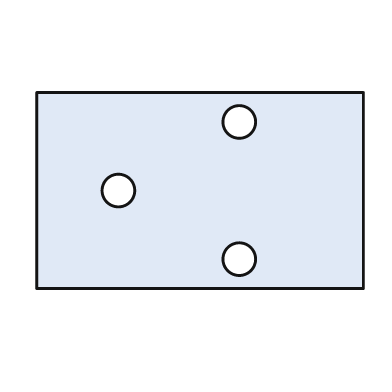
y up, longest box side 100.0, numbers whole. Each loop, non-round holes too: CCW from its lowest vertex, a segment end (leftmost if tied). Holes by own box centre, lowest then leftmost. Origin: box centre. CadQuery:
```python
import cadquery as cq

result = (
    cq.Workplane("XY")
    .moveTo(-50.0, -30.0)
    .lineTo(50.0, -30.0)
    .lineTo(50.0, 30.0)
    .lineTo(-50.0, 30.0)
    .close()
    .moveTo(12.0, -21.0)
    .circle(5.0)
    .moveTo(-25.0, 0.0)
    .circle(5.0)
    .moveTo(12.0, 21.0)
    .circle(5.0)
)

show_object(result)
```